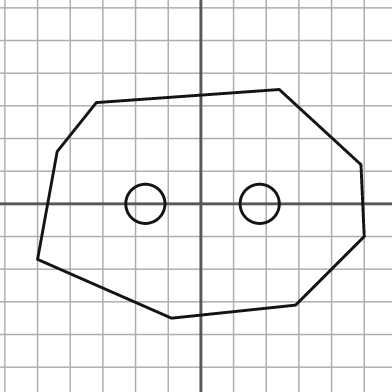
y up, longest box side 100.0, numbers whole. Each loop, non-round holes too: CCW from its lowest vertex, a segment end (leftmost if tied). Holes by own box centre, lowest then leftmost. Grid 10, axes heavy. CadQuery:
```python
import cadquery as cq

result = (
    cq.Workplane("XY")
    .moveTo(-9.0, -35.0)
    .lineTo(29.0, -31.0)
    .lineTo(50.0, -10.0)
    .lineTo(49.0, 12.0)
    .lineTo(24.0, 35.0)
    .lineTo(-32.0, 31.0)
    .lineTo(-44.0, 16.0)
    .lineTo(-50.0, -17.0)
    .close()
    .moveTo(-17.0, 0.0)
    .circle(6.0)
    .moveTo(18.0, 0.0)
    .circle(6.0)
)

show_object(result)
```